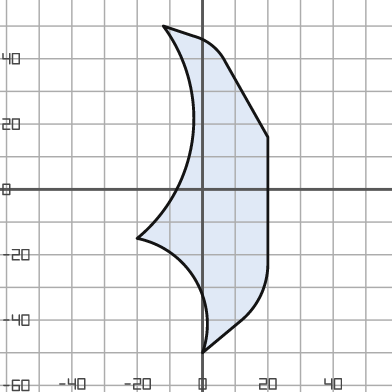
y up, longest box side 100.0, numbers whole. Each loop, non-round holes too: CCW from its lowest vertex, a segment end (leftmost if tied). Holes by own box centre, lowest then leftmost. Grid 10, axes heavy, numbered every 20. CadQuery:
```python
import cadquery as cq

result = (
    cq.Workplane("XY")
    .moveTo(0.0, -50.0)
    .lineTo(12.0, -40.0)
    .threePointArc((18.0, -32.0), (20.0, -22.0))
    .lineTo(20.0, 16.0)
    .lineTo(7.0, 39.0)
    .threePointArc((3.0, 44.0), (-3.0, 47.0))
    .lineTo(-12.0, 50.0)
    .threePointArc((-3.0, 16.0), (-20.0, -15.0))
    .threePointArc((-2.0, -28.0), (0.0, -50.0))
    .close()
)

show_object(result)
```